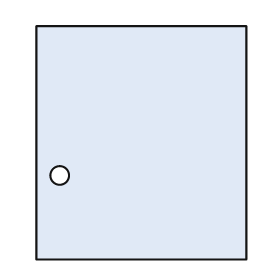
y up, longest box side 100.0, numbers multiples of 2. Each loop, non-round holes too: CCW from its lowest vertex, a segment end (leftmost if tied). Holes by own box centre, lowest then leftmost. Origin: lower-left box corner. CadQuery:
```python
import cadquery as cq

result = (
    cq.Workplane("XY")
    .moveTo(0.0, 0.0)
    .lineTo(90.0, 0.0)
    .lineTo(90.0, 100.0)
    .lineTo(0.0, 100.0)
    .close()
    .moveTo(10.0, 36.0)
    .circle(4.0)
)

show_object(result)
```